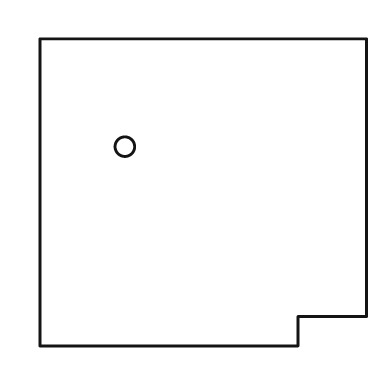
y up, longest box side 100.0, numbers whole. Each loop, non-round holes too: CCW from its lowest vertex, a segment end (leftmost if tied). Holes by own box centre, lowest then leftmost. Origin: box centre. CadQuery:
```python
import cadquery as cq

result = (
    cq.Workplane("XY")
    .moveTo(-50.0, -47.0)
    .lineTo(29.0, -47.0)
    .lineTo(29.0, -38.0)
    .lineTo(50.0, -38.0)
    .lineTo(50.0, 47.0)
    .lineTo(-50.0, 47.0)
    .close()
    .moveTo(-24.0, 14.0)
    .circle(3.0)
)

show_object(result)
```